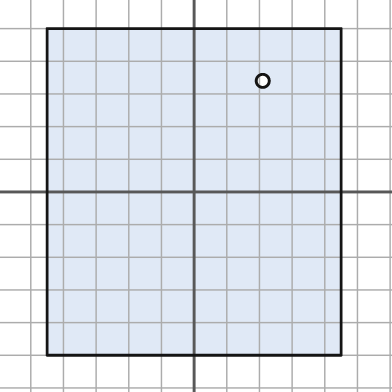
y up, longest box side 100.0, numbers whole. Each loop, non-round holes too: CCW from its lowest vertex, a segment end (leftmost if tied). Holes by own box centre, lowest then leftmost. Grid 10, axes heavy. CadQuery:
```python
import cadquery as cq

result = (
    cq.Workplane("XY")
    .moveTo(-45.0, -50.0)
    .lineTo(45.0, -50.0)
    .lineTo(45.0, 50.0)
    .lineTo(-45.0, 50.0)
    .close()
    .moveTo(21.0, 34.0)
    .circle(2.0)
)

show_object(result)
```